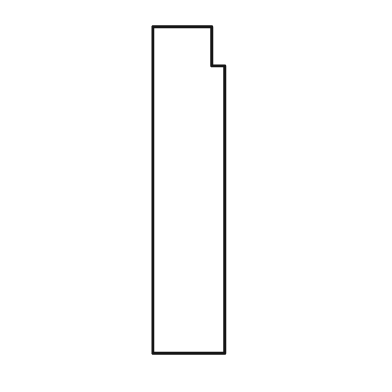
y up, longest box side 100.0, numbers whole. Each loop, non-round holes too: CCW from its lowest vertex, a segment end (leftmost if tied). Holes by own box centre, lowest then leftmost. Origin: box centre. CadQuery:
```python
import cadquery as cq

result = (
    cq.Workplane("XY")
    .moveTo(-11.0, -50.0)
    .lineTo(11.0, -50.0)
    .lineTo(11.0, 38.0)
    .lineTo(7.0, 38.0)
    .lineTo(7.0, 50.0)
    .lineTo(-11.0, 50.0)
    .close()
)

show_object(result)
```